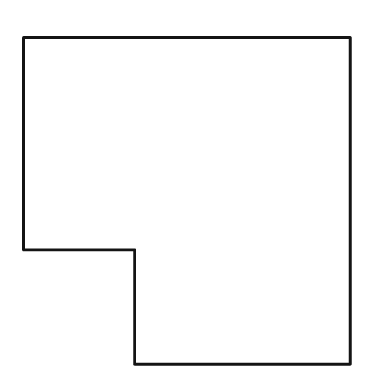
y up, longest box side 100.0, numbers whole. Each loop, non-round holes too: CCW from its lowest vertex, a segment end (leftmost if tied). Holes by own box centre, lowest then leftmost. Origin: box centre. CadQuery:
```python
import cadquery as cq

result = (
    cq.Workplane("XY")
    .moveTo(-16.0, -50.0)
    .lineTo(50.0, -50.0)
    .lineTo(50.0, 50.0)
    .lineTo(-50.0, 50.0)
    .lineTo(-50.0, -15.0)
    .lineTo(-16.0, -15.0)
    .close()
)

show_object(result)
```